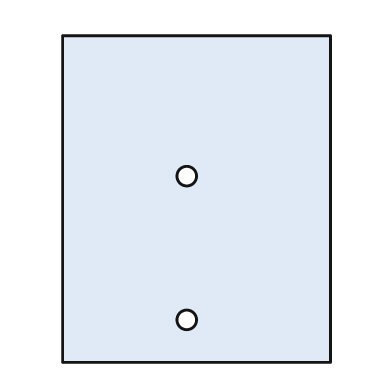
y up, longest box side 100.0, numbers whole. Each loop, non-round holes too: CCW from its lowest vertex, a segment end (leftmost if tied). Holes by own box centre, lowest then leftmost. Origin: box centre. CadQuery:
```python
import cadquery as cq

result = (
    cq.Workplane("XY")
    .moveTo(-41.0, -50.0)
    .lineTo(41.0, -50.0)
    .lineTo(41.0, 50.0)
    .lineTo(-41.0, 50.0)
    .close()
    .moveTo(-3.0, -37.0)
    .circle(3.0)
    .moveTo(-3.0, 7.0)
    .circle(3.0)
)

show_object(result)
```